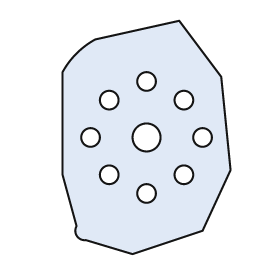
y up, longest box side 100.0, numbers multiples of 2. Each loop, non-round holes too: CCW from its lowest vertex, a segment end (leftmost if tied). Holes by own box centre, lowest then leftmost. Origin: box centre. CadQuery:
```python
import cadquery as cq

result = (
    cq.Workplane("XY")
    .moveTo(-6.0, -50.0)
    .lineTo(24.0, -40.0)
    .lineTo(36.0, -14.0)
    .lineTo(32.0, 26.0)
    .lineTo(14.0, 50.0)
    .lineTo(-22.0, 42.0)
    .threePointArc((-30.0, 36.0), (-36.0, 28.0))
    .lineTo(-36.0, -16.0)
    .lineTo(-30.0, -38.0)
    .threePointArc((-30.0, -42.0), (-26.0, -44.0))
    .close()
    .moveTo(0.0, -24.0)
    .circle(4.0)
    .moveTo(-16.0, -16.0)
    .circle(4.0)
    .moveTo(16.0, -16.0)
    .circle(4.0)
    .moveTo(-24.0, 0.0)
    .circle(4.0)
    .moveTo(0.0, 0.0)
    .circle(6.0)
    .moveTo(24.0, 0.0)
    .circle(4.0)
    .moveTo(-16.0, 16.0)
    .circle(4.0)
    .moveTo(16.0, 16.0)
    .circle(4.0)
    .moveTo(0.0, 24.0)
    .circle(4.0)
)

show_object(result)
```